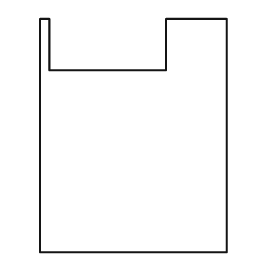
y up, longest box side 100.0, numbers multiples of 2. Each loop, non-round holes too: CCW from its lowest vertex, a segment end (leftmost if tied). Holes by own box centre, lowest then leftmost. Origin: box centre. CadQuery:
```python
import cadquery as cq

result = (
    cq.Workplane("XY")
    .moveTo(-40.0, -50.0)
    .lineTo(40.0, -50.0)
    .lineTo(40.0, 50.0)
    .lineTo(14.0, 50.0)
    .lineTo(14.0, 28.0)
    .lineTo(-36.0, 28.0)
    .lineTo(-36.0, 50.0)
    .lineTo(-40.0, 50.0)
    .close()
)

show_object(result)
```